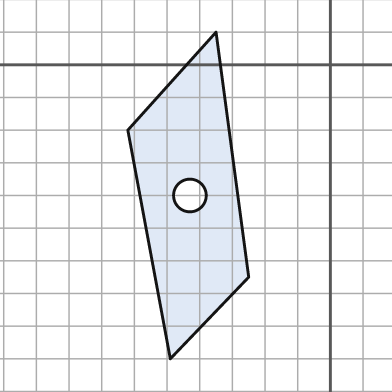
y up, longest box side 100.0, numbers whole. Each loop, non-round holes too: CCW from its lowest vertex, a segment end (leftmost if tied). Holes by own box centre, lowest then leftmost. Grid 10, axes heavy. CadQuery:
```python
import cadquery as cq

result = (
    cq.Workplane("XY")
    .moveTo(-49.0, -90.0)
    .lineTo(-25.0, -65.0)
    .lineTo(-35.0, 10.0)
    .lineTo(-62.0, -20.0)
    .close()
    .moveTo(-43.0, -40.0)
    .circle(5.0)
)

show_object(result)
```